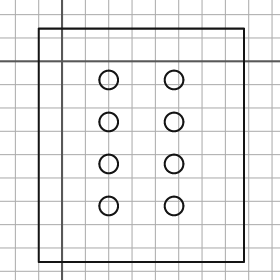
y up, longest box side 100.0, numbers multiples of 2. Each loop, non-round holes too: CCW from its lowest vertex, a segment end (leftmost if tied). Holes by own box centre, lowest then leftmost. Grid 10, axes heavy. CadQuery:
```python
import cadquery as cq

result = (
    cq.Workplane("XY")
    .moveTo(-10.0, -86.0)
    .lineTo(78.0, -86.0)
    .lineTo(78.0, 14.0)
    .lineTo(-10.0, 14.0)
    .close()
    .moveTo(20.0, -62.0)
    .circle(4.0)
    .moveTo(48.0, -62.0)
    .circle(4.0)
    .moveTo(20.0, -44.0)
    .circle(4.0)
    .moveTo(48.0, -44.0)
    .circle(4.0)
    .moveTo(20.0, -26.0)
    .circle(4.0)
    .moveTo(48.0, -26.0)
    .circle(4.0)
    .moveTo(20.0, -8.0)
    .circle(4.0)
    .moveTo(48.0, -8.0)
    .circle(4.0)
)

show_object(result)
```